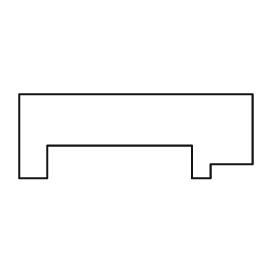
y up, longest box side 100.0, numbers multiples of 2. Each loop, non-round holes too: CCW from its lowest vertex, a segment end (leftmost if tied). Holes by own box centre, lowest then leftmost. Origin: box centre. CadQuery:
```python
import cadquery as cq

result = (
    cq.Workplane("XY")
    .moveTo(-50.0, -18.0)
    .lineTo(-38.0, -18.0)
    .lineTo(-38.0, -4.0)
    .lineTo(24.0, -4.0)
    .lineTo(24.0, -18.0)
    .lineTo(32.0, -18.0)
    .lineTo(32.0, -12.0)
    .lineTo(50.0, -12.0)
    .lineTo(50.0, 18.0)
    .lineTo(-50.0, 18.0)
    .close()
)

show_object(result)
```